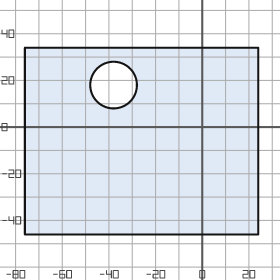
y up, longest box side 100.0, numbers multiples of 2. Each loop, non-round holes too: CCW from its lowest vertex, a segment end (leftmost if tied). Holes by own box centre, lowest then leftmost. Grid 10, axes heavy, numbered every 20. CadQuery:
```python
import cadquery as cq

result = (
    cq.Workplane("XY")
    .moveTo(-76.0, -46.0)
    .lineTo(24.0, -46.0)
    .lineTo(24.0, 34.0)
    .lineTo(-76.0, 34.0)
    .close()
    .moveTo(-38.0, 18.0)
    .circle(10.0)
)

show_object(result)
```